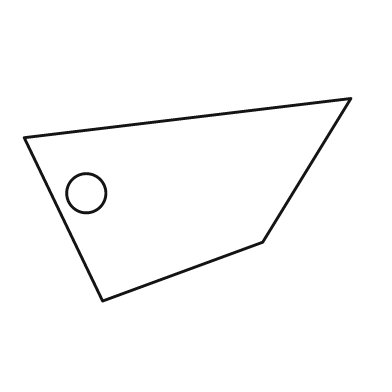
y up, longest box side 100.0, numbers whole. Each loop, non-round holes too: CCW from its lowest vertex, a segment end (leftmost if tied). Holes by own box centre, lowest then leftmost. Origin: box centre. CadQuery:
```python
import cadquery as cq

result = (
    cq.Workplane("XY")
    .moveTo(-26.0, -31.0)
    .lineTo(23.0, -13.0)
    .lineTo(50.0, 31.0)
    .lineTo(-50.0, 19.0)
    .close()
    .moveTo(-31.0, 2.0)
    .circle(6.0)
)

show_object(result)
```